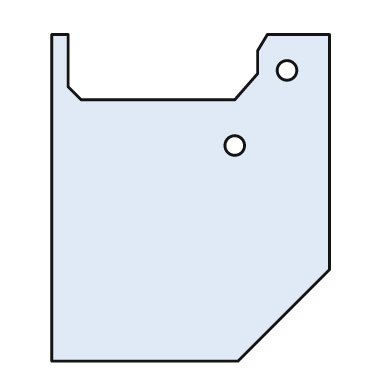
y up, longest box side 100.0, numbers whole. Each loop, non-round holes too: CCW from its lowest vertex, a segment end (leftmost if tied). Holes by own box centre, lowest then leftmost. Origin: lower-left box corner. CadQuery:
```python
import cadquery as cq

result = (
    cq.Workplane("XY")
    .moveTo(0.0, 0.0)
    .lineTo(57.0, 0.0)
    .lineTo(85.0, 28.0)
    .lineTo(85.0, 100.0)
    .lineTo(66.0, 100.0)
    .lineTo(63.0, 95.0)
    .lineTo(63.0, 88.0)
    .lineTo(56.0, 80.0)
    .lineTo(9.0, 80.0)
    .lineTo(5.0, 84.0)
    .lineTo(5.0, 100.0)
    .lineTo(0.0, 100.0)
    .close()
    .moveTo(56.0, 66.0)
    .circle(3.0)
    .moveTo(72.0, 89.0)
    .circle(3.0)
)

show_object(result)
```